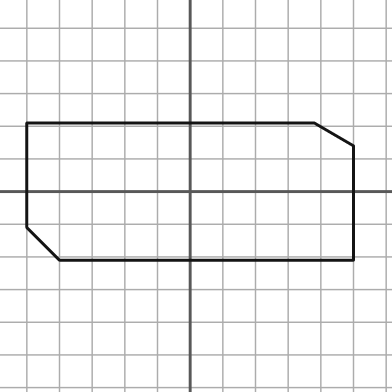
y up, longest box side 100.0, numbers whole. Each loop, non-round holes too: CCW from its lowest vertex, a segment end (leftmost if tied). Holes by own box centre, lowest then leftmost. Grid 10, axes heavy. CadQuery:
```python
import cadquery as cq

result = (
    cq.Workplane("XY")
    .moveTo(-40.0, -21.0)
    .lineTo(50.0, -21.0)
    .lineTo(50.0, 14.0)
    .lineTo(38.0, 21.0)
    .lineTo(-50.0, 21.0)
    .lineTo(-50.0, -11.0)
    .close()
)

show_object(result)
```